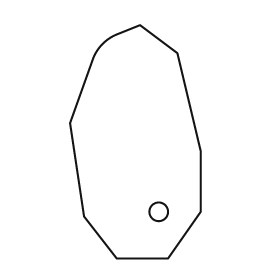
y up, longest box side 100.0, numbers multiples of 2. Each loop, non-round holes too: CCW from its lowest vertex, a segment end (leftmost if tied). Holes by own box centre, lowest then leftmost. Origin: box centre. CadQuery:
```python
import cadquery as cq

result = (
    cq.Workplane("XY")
    .moveTo(-8.0, -50.0)
    .lineTo(14.0, -50.0)
    .lineTo(28.0, -30.0)
    .lineTo(28.0, -4.0)
    .lineTo(18.0, 38.0)
    .lineTo(2.0, 50.0)
    .lineTo(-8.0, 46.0)
    .threePointArc((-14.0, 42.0), (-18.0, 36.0))
    .lineTo(-28.0, 8.0)
    .lineTo(-22.0, -32.0)
    .close()
    .moveTo(10.0, -30.0)
    .circle(4.0)
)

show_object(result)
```